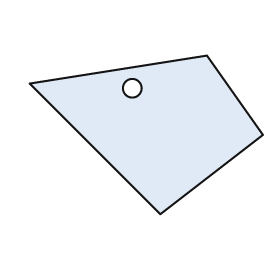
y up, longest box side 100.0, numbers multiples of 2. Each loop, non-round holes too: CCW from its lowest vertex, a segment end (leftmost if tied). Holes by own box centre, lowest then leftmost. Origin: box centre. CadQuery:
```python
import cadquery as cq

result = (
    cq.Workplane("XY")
    .moveTo(6.0, -34.0)
    .lineTo(50.0, 0.0)
    .lineTo(26.0, 34.0)
    .lineTo(-50.0, 22.0)
    .close()
    .moveTo(-6.0, 20.0)
    .circle(4.0)
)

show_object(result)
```